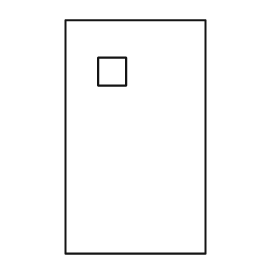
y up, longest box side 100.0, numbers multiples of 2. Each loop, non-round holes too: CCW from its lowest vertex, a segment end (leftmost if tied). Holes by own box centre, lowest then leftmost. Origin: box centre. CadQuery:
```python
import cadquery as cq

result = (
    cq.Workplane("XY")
    .moveTo(-30.0, -50.0)
    .lineTo(30.0, -50.0)
    .lineTo(30.0, 50.0)
    .lineTo(-30.0, 50.0)
    .close()
    .moveTo(-16.0, 22.0)
    .lineTo(-4.0, 22.0)
    .lineTo(-4.0, 34.0)
    .lineTo(-16.0, 34.0)
    .close()
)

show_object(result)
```